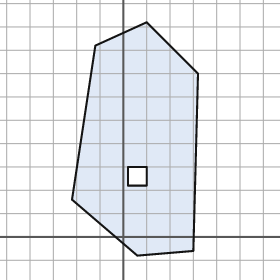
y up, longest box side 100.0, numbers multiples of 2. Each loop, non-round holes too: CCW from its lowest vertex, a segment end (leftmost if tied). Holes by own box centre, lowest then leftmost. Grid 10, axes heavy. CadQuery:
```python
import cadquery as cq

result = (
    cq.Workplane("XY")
    .moveTo(6.0, -8.0)
    .lineTo(30.0, -6.0)
    .lineTo(32.0, 70.0)
    .lineTo(10.0, 92.0)
    .lineTo(-12.0, 82.0)
    .lineTo(-22.0, 16.0)
    .close()
    .moveTo(2.0, 22.0)
    .lineTo(10.0, 22.0)
    .lineTo(10.0, 30.0)
    .lineTo(2.0, 30.0)
    .close()
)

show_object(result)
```